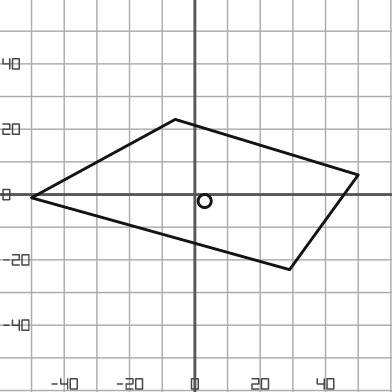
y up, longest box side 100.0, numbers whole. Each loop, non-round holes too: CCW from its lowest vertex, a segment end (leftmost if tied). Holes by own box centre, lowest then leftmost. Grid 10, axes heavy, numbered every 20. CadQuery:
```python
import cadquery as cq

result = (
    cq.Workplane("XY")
    .moveTo(29.0, -23.0)
    .lineTo(50.0, 6.0)
    .lineTo(-6.0, 23.0)
    .lineTo(-50.0, -1.0)
    .close()
    .moveTo(3.0, -2.0)
    .circle(2.0)
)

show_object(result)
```